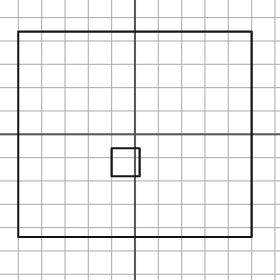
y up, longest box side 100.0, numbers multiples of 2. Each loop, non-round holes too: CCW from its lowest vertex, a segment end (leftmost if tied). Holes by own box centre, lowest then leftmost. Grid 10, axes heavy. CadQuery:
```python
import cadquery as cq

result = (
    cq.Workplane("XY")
    .moveTo(-50.0, -44.0)
    .lineTo(50.0, -44.0)
    .lineTo(50.0, 44.0)
    .lineTo(-50.0, 44.0)
    .close()
    .moveTo(-10.0, -18.0)
    .lineTo(2.0, -18.0)
    .lineTo(2.0, -6.0)
    .lineTo(-10.0, -6.0)
    .close()
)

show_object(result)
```